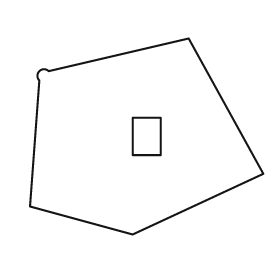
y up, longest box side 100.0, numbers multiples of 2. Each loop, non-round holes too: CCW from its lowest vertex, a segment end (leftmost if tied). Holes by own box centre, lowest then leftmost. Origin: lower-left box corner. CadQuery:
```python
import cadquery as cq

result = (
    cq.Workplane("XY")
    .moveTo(44.0, 0.0)
    .lineTo(100.0, 26.0)
    .lineTo(68.0, 84.0)
    .lineTo(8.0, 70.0)
    .threePointArc((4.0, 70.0), (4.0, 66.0))
    .lineTo(0.0, 12.0)
    .close()
    .moveTo(44.0, 34.0)
    .lineTo(56.0, 34.0)
    .lineTo(56.0, 50.0)
    .lineTo(44.0, 50.0)
    .close()
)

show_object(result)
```